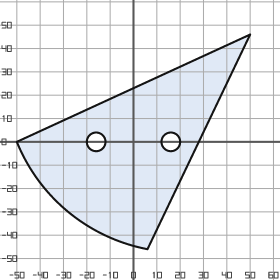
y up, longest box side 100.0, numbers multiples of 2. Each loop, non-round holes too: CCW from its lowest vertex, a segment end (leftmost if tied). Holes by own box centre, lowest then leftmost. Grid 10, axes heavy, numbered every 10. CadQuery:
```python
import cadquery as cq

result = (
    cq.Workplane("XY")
    .moveTo(6.0, -46.0)
    .lineTo(50.0, 46.0)
    .lineTo(-50.0, 0.0)
    .threePointArc((-28.0, -30.0), (6.0, -46.0))
    .close()
    .moveTo(-16.0, 0.0)
    .circle(4.0)
    .moveTo(16.0, 0.0)
    .circle(4.0)
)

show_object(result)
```